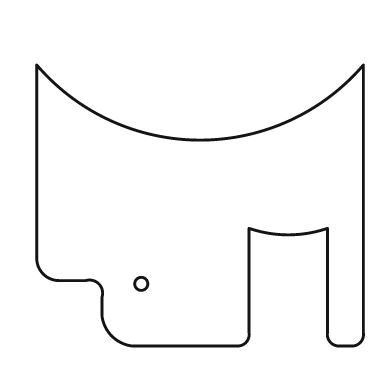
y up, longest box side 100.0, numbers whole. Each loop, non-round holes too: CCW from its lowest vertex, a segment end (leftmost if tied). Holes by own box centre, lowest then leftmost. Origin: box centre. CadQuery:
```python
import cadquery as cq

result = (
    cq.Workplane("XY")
    .moveTo(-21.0, -43.0)
    .lineTo(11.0, -43.0)
    .threePointArc((14.0, -42.0), (15.0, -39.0))
    .lineTo(15.0, -7.0)
    .threePointArc((27.0, -9.0), (39.0, -7.0))
    .lineTo(39.0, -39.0)
    .threePointArc((40.0, -42.0), (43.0, -43.0))
    .lineTo(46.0, -43.0)
    .threePointArc((49.0, -42.0), (50.0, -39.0))
    .lineTo(50.0, 43.0)
    .threePointArc((0.0, 20.0), (-50.0, 43.0))
    .lineTo(-50.0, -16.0)
    .threePointArc((-48.0, -21.0), (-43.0, -23.0))
    .lineTo(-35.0, -23.0)
    .threePointArc((-31.0, -24.0), (-30.0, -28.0))
    .lineTo(-30.0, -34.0)
    .threePointArc((-27.0, -40.0), (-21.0, -43.0))
    .close()
    .moveTo(-18.0, -24.0)
    .circle(2.0)
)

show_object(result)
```